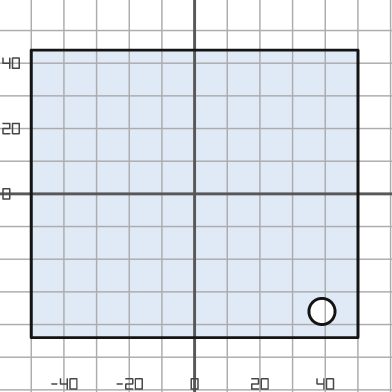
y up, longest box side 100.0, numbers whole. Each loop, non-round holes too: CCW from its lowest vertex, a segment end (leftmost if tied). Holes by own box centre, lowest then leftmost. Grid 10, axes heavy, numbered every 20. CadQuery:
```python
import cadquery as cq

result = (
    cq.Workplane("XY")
    .moveTo(-50.0, -44.0)
    .lineTo(50.0, -44.0)
    .lineTo(50.0, 44.0)
    .lineTo(-50.0, 44.0)
    .close()
    .moveTo(39.0, -36.0)
    .circle(4.0)
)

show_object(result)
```